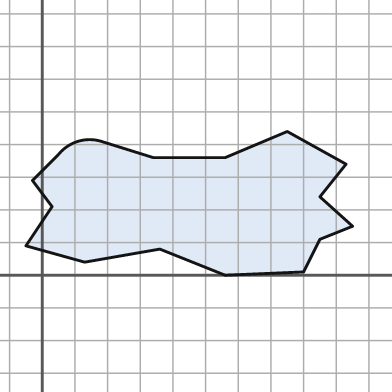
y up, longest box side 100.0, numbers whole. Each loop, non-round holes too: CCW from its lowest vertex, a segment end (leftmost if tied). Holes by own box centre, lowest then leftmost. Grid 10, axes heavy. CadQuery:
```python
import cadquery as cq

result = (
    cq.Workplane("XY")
    .moveTo(56.0, 0.0)
    .lineTo(80.0, 1.0)
    .lineTo(85.0, 11.0)
    .lineTo(95.0, 15.0)
    .lineTo(85.0, 24.0)
    .lineTo(93.0, 34.0)
    .lineTo(75.0, 44.0)
    .lineTo(56.0, 36.0)
    .lineTo(34.0, 36.0)
    .lineTo(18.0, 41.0)
    .threePointArc((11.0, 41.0), (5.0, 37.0))
    .lineTo(-3.0, 29.0)
    .lineTo(3.0, 21.0)
    .lineTo(-5.0, 9.0)
    .lineTo(13.0, 4.0)
    .lineTo(36.0, 8.0)
    .close()
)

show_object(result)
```